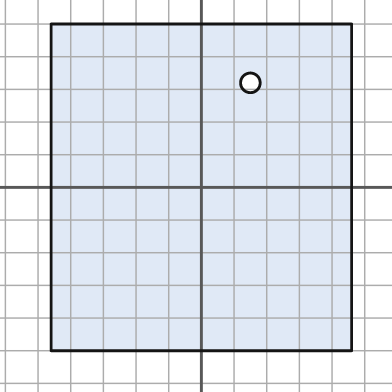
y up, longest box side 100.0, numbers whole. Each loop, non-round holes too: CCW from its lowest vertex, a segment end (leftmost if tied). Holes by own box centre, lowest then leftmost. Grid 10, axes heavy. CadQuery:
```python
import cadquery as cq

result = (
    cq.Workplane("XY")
    .moveTo(-46.0, -50.0)
    .lineTo(46.0, -50.0)
    .lineTo(46.0, 50.0)
    .lineTo(-46.0, 50.0)
    .close()
    .moveTo(15.0, 32.0)
    .circle(3.0)
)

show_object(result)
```